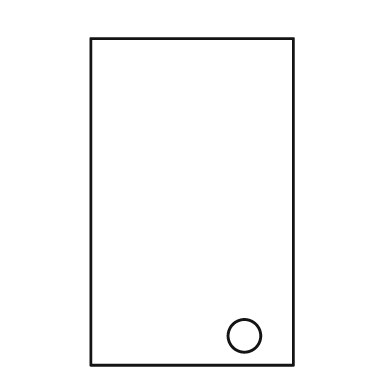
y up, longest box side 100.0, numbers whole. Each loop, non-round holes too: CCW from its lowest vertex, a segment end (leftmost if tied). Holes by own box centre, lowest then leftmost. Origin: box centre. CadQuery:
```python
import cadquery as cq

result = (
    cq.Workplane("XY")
    .moveTo(-31.0, -50.0)
    .lineTo(31.0, -50.0)
    .lineTo(31.0, 50.0)
    .lineTo(-31.0, 50.0)
    .close()
    .moveTo(16.0, -41.0)
    .circle(5.0)
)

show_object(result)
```